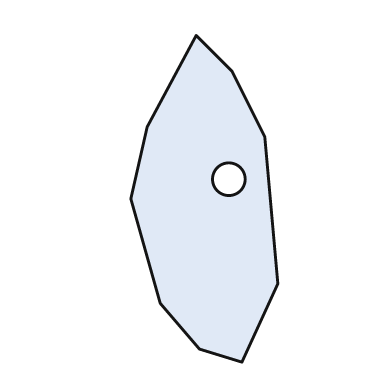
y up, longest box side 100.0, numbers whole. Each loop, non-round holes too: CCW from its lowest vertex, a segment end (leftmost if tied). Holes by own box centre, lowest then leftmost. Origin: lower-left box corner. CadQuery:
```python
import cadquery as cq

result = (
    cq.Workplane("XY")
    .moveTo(34.0, 0.0)
    .lineTo(45.0, 24.0)
    .lineTo(41.0, 69.0)
    .lineTo(31.0, 89.0)
    .lineTo(20.0, 100.0)
    .lineTo(5.0, 72.0)
    .lineTo(0.0, 50.0)
    .lineTo(9.0, 18.0)
    .lineTo(21.0, 4.0)
    .close()
    .moveTo(30.0, 56.0)
    .circle(5.0)
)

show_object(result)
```